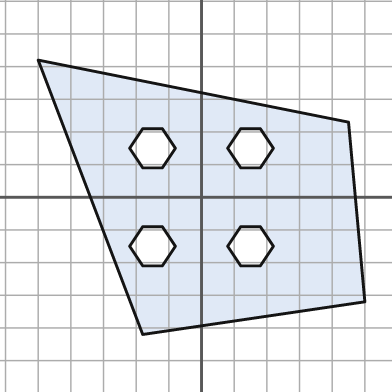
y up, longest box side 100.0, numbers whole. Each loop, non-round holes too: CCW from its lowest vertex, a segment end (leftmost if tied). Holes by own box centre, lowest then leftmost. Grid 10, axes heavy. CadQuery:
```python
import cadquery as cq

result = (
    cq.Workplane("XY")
    .moveTo(-18.0, -42.0)
    .lineTo(50.0, -32.0)
    .lineTo(45.0, 23.0)
    .lineTo(-50.0, 42.0)
    .close()
    .moveTo(-18.0, -21.0)
    .lineTo(-12.0, -21.0)
    .lineTo(-8.0, -15.0)
    .lineTo(-12.0, -9.0)
    .lineTo(-18.0, -9.0)
    .lineTo(-22.0, -15.0)
    .close()
    .moveTo(12.0, -21.0)
    .lineTo(18.0, -21.0)
    .lineTo(22.0, -15.0)
    .lineTo(18.0, -9.0)
    .lineTo(12.0, -9.0)
    .lineTo(8.0, -15.0)
    .close()
    .moveTo(-18.0, 9.0)
    .lineTo(-12.0, 9.0)
    .lineTo(-8.0, 15.0)
    .lineTo(-12.0, 21.0)
    .lineTo(-18.0, 21.0)
    .lineTo(-22.0, 15.0)
    .close()
    .moveTo(12.0, 9.0)
    .lineTo(18.0, 9.0)
    .lineTo(22.0, 15.0)
    .lineTo(18.0, 21.0)
    .lineTo(12.0, 21.0)
    .lineTo(8.0, 15.0)
    .close()
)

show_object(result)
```